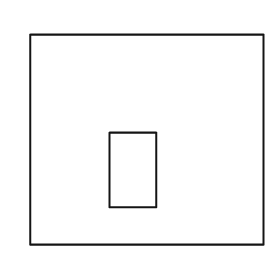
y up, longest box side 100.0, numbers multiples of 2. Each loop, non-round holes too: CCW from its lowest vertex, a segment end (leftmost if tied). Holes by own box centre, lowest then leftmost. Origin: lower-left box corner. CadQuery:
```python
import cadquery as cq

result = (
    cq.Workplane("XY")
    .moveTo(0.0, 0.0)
    .lineTo(100.0, 0.0)
    .lineTo(100.0, 90.0)
    .lineTo(0.0, 90.0)
    .close()
    .moveTo(34.0, 16.0)
    .lineTo(54.0, 16.0)
    .lineTo(54.0, 48.0)
    .lineTo(34.0, 48.0)
    .close()
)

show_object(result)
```